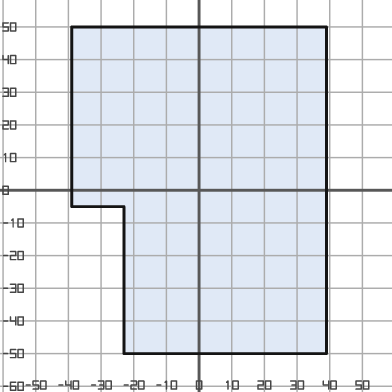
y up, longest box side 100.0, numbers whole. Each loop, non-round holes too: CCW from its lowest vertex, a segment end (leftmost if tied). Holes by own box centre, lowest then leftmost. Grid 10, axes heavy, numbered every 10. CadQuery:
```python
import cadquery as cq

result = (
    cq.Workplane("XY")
    .moveTo(-23.0, -50.0)
    .lineTo(39.0, -50.0)
    .lineTo(39.0, 50.0)
    .lineTo(-39.0, 50.0)
    .lineTo(-39.0, -5.0)
    .lineTo(-23.0, -5.0)
    .close()
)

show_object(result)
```